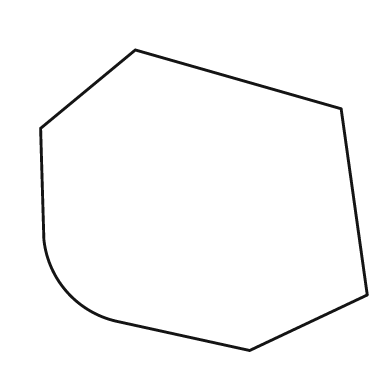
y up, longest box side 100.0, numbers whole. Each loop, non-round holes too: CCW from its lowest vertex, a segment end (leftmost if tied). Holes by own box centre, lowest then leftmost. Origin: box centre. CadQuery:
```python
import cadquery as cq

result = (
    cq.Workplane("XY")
    .moveTo(14.0, -46.0)
    .lineTo(50.0, -29.0)
    .lineTo(42.0, 28.0)
    .lineTo(-21.0, 46.0)
    .lineTo(-50.0, 22.0)
    .lineTo(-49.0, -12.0)
    .threePointArc((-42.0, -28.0), (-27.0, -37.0))
    .close()
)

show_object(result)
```